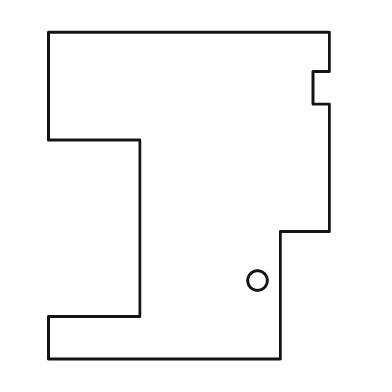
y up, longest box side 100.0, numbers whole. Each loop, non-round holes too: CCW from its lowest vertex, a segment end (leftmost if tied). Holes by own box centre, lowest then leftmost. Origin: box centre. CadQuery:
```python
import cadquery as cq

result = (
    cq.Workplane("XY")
    .moveTo(-43.0, -50.0)
    .lineTo(28.0, -50.0)
    .lineTo(28.0, -11.0)
    .lineTo(43.0, -11.0)
    .lineTo(43.0, 28.0)
    .lineTo(38.0, 28.0)
    .lineTo(38.0, 38.0)
    .lineTo(43.0, 38.0)
    .lineTo(43.0, 50.0)
    .lineTo(-43.0, 50.0)
    .lineTo(-43.0, 17.0)
    .lineTo(-15.0, 17.0)
    .lineTo(-15.0, -37.0)
    .lineTo(-43.0, -37.0)
    .close()
    .moveTo(21.0, -26.0)
    .circle(3.0)
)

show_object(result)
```